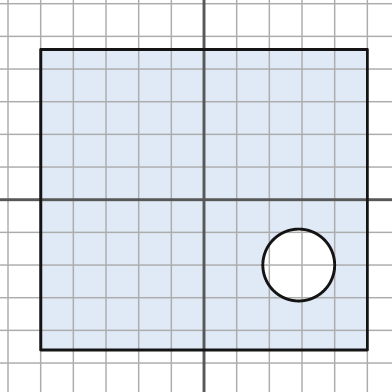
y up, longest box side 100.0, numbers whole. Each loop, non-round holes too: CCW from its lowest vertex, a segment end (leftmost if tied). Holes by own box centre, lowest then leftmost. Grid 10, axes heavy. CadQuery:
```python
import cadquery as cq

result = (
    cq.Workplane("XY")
    .moveTo(-50.0, -46.0)
    .lineTo(50.0, -46.0)
    .lineTo(50.0, 46.0)
    .lineTo(-50.0, 46.0)
    .close()
    .moveTo(29.0, -20.0)
    .circle(11.0)
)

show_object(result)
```